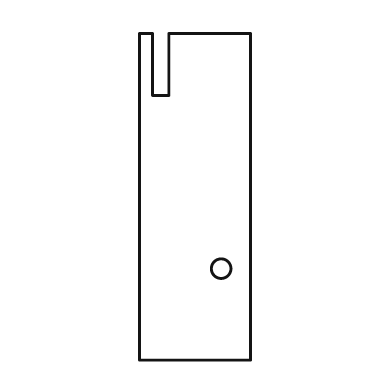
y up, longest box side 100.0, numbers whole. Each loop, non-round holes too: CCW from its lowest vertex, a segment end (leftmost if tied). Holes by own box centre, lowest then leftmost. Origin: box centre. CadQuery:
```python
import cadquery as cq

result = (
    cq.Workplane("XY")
    .moveTo(-17.0, -50.0)
    .lineTo(17.0, -50.0)
    .lineTo(17.0, 50.0)
    .lineTo(-8.0, 50.0)
    .lineTo(-8.0, 31.0)
    .lineTo(-13.0, 31.0)
    .lineTo(-13.0, 50.0)
    .lineTo(-17.0, 50.0)
    .close()
    .moveTo(8.0, -22.0)
    .circle(3.0)
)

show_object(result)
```